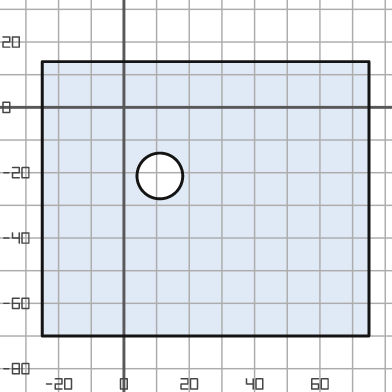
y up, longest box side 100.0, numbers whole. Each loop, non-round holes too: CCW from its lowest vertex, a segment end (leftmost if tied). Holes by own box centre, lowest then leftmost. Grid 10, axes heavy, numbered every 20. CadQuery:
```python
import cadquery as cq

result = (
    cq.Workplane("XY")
    .moveTo(-25.0, -70.0)
    .lineTo(75.0, -70.0)
    .lineTo(75.0, 14.0)
    .lineTo(-25.0, 14.0)
    .close()
    .moveTo(11.0, -21.0)
    .circle(7.0)
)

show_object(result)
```